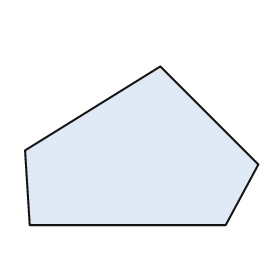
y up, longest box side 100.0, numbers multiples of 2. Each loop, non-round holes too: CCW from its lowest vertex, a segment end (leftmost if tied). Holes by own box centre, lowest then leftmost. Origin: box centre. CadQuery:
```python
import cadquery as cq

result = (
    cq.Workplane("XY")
    .moveTo(-48.0, -34.0)
    .lineTo(36.0, -34.0)
    .lineTo(50.0, -8.0)
    .lineTo(8.0, 34.0)
    .lineTo(-50.0, -2.0)
    .close()
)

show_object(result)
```